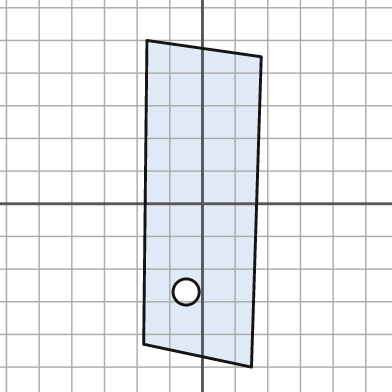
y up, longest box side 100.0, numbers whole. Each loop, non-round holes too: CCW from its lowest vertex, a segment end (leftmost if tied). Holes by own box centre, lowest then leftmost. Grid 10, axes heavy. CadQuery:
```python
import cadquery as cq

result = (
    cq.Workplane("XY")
    .moveTo(15.0, -50.0)
    .lineTo(18.0, 45.0)
    .lineTo(-17.0, 50.0)
    .lineTo(-18.0, -43.0)
    .close()
    .moveTo(-5.0, -27.0)
    .circle(4.0)
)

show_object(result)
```